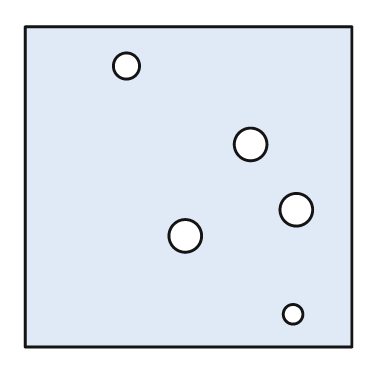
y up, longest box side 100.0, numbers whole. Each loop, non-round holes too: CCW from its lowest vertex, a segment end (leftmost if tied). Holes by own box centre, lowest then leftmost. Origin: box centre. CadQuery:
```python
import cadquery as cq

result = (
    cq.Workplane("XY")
    .moveTo(-50.0, -49.0)
    .lineTo(50.0, -49.0)
    .lineTo(50.0, 49.0)
    .lineTo(-50.0, 49.0)
    .close()
    .moveTo(32.0, -39.0)
    .circle(3.0)
    .moveTo(-1.0, -15.0)
    .circle(5.0)
    .moveTo(33.0, -7.0)
    .circle(5.0)
    .moveTo(19.0, 13.0)
    .circle(5.0)
    .moveTo(-19.0, 37.0)
    .circle(4.0)
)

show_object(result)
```